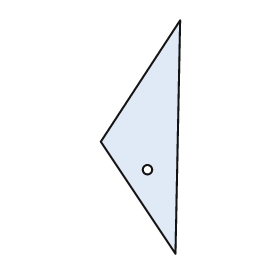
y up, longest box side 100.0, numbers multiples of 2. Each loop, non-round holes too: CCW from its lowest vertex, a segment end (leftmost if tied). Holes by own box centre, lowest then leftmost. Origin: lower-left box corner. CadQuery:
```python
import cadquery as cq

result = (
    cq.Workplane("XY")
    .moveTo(32.0, 0.0)
    .lineTo(34.0, 100.0)
    .lineTo(0.0, 48.0)
    .close()
    .moveTo(20.0, 36.0)
    .circle(2.0)
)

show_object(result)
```